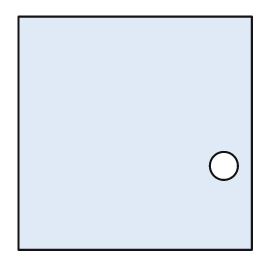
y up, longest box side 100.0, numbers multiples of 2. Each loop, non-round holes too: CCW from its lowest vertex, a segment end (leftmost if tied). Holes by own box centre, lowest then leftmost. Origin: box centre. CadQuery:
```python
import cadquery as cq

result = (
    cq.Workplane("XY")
    .moveTo(-50.0, -50.0)
    .lineTo(50.0, -50.0)
    .lineTo(50.0, 50.0)
    .lineTo(-50.0, 50.0)
    .close()
    .moveTo(38.0, -14.0)
    .circle(6.0)
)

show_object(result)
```